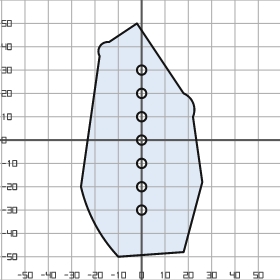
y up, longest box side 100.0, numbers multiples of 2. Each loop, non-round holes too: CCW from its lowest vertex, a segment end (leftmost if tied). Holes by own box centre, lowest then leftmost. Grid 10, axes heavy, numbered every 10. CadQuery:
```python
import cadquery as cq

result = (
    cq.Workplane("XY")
    .moveTo(-10.0, -50.0)
    .lineTo(18.0, -48.0)
    .lineTo(26.0, -18.0)
    .lineTo(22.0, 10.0)
    .threePointArc((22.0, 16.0), (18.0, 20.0))
    .lineTo(-2.0, 50.0)
    .lineTo(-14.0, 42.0)
    .threePointArc((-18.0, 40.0), (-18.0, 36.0))
    .lineTo(-26.0, -20.0)
    .threePointArc((-20.0, -36.0), (-10.0, -50.0))
    .close()
    .moveTo(0.0, -30.0)
    .circle(2.0)
    .moveTo(0.0, -20.0)
    .circle(2.0)
    .moveTo(0.0, -10.0)
    .circle(2.0)
    .moveTo(0.0, 0.0)
    .circle(2.0)
    .moveTo(0.0, 10.0)
    .circle(2.0)
    .moveTo(0.0, 20.0)
    .circle(2.0)
    .moveTo(0.0, 30.0)
    .circle(2.0)
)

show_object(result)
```